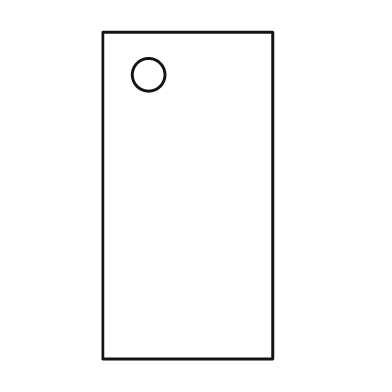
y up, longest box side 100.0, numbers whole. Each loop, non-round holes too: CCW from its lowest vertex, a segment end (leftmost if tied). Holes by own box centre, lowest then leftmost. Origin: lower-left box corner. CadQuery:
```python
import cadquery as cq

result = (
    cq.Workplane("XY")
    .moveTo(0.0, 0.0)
    .lineTo(52.0, 0.0)
    .lineTo(52.0, 100.0)
    .lineTo(0.0, 100.0)
    .close()
    .moveTo(14.0, 87.0)
    .circle(5.0)
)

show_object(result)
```